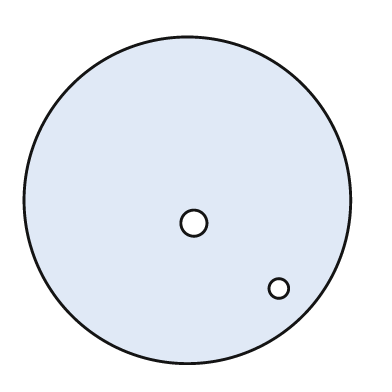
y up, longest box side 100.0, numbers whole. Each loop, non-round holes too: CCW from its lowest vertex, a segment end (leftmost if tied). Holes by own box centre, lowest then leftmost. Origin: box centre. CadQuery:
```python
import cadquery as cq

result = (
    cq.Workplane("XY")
    .moveTo(0.0, 0.0)
    .circle(50.0)
    .moveTo(28.0, -27.0)
    .circle(3.0)
    .moveTo(2.0, -7.0)
    .circle(4.0)
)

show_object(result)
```